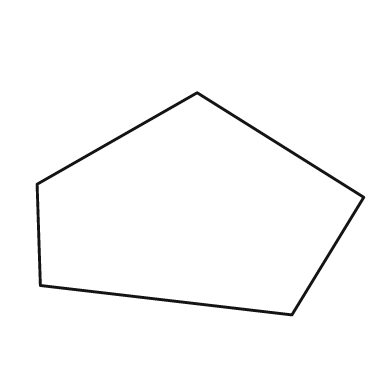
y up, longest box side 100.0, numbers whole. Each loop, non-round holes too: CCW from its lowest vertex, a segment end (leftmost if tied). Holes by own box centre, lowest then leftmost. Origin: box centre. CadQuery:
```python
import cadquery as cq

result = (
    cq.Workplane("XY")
    .moveTo(28.0, -34.0)
    .lineTo(50.0, 2.0)
    .lineTo(-1.0, 34.0)
    .lineTo(-50.0, 6.0)
    .lineTo(-49.0, -25.0)
    .close()
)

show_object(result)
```